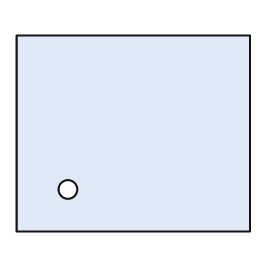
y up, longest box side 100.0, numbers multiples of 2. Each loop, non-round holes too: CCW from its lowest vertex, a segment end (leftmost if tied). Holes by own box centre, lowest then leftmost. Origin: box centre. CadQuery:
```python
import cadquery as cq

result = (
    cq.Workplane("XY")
    .moveTo(-50.0, -42.0)
    .lineTo(50.0, -42.0)
    .lineTo(50.0, 42.0)
    .lineTo(-50.0, 42.0)
    .close()
    .moveTo(-28.0, -24.0)
    .circle(4.0)
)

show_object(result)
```